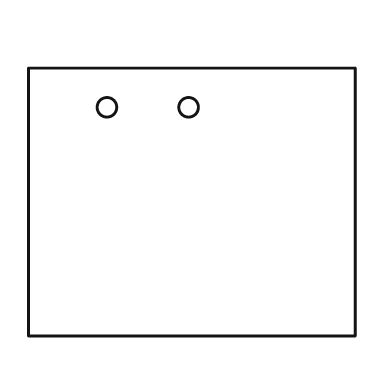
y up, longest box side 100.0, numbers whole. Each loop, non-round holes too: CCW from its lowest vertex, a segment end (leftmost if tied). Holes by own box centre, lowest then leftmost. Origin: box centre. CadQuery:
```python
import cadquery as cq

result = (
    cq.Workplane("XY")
    .moveTo(-50.0, -41.0)
    .lineTo(50.0, -41.0)
    .lineTo(50.0, 41.0)
    .lineTo(-50.0, 41.0)
    .close()
    .moveTo(-26.0, 29.0)
    .circle(3.0)
    .moveTo(-1.0, 29.0)
    .circle(3.0)
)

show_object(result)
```